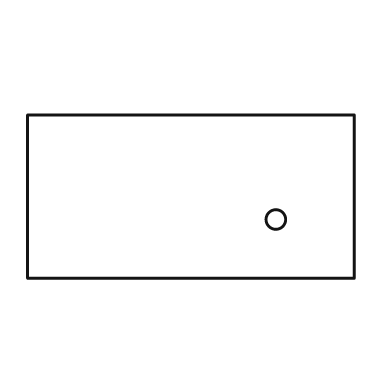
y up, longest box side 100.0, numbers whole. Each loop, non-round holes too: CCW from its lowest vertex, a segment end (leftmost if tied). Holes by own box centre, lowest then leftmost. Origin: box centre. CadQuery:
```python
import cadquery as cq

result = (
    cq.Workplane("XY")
    .moveTo(-50.0, -25.0)
    .lineTo(50.0, -25.0)
    .lineTo(50.0, 25.0)
    .lineTo(-50.0, 25.0)
    .close()
    .moveTo(26.0, -7.0)
    .circle(3.0)
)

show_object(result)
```